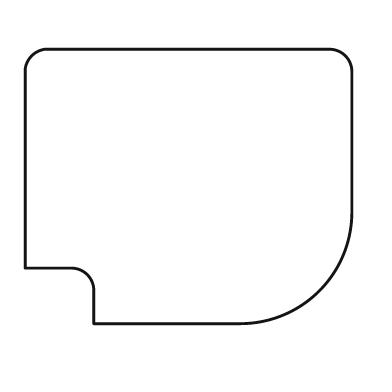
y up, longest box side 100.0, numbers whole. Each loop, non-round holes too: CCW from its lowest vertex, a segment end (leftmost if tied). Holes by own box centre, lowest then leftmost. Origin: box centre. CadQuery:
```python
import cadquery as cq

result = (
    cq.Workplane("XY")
    .moveTo(-29.0, -42.0)
    .lineTo(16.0, -42.0)
    .threePointArc((40.0, -32.0), (50.0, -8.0))
    .lineTo(50.0, 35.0)
    .threePointArc((48.0, 40.0), (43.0, 42.0))
    .lineTo(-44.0, 42.0)
    .threePointArc((-48.0, 40.0), (-50.0, 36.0))
    .lineTo(-50.0, -25.0)
    .lineTo(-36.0, -25.0)
    .threePointArc((-31.0, -27.0), (-29.0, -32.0))
    .close()
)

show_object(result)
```